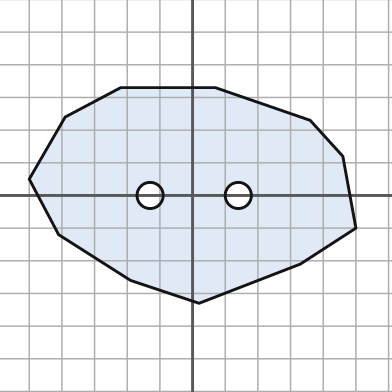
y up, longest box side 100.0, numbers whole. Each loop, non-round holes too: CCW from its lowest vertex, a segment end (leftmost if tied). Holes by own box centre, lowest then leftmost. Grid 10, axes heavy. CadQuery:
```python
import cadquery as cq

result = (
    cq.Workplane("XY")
    .moveTo(2.0, -33.0)
    .lineTo(33.0, -21.0)
    .lineTo(50.0, -10.0)
    .lineTo(46.0, 12.0)
    .lineTo(36.0, 23.0)
    .lineTo(7.0, 33.0)
    .lineTo(-22.0, 33.0)
    .lineTo(-39.0, 24.0)
    .lineTo(-50.0, 5.0)
    .lineTo(-41.0, -12.0)
    .lineTo(-19.0, -26.0)
    .close()
    .moveTo(-13.0, 0.0)
    .circle(4.0)
    .moveTo(14.0, 0.0)
    .circle(4.0)
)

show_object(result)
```